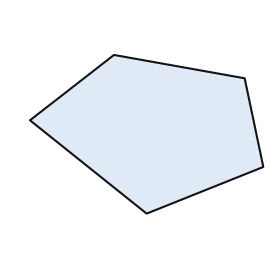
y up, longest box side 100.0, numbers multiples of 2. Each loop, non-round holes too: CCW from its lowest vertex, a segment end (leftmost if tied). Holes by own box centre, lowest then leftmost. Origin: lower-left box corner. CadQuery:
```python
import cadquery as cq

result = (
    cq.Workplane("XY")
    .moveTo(50.0, 0.0)
    .lineTo(100.0, 20.0)
    .lineTo(92.0, 58.0)
    .lineTo(36.0, 68.0)
    .lineTo(0.0, 40.0)
    .close()
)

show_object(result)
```